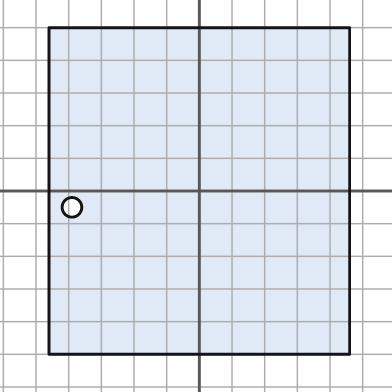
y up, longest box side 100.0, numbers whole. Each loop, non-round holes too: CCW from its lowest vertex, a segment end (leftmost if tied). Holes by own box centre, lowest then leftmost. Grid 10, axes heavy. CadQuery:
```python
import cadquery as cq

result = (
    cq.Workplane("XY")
    .moveTo(-46.0, -50.0)
    .lineTo(46.0, -50.0)
    .lineTo(46.0, 50.0)
    .lineTo(-46.0, 50.0)
    .close()
    .moveTo(-39.0, -5.0)
    .circle(3.0)
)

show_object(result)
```